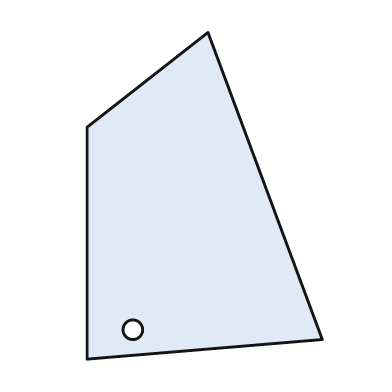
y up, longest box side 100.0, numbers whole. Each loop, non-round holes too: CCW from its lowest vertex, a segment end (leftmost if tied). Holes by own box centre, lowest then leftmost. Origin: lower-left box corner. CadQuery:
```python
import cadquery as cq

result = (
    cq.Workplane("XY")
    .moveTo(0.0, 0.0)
    .lineTo(72.0, 6.0)
    .lineTo(37.0, 100.0)
    .lineTo(0.0, 71.0)
    .close()
    .moveTo(14.0, 9.0)
    .circle(3.0)
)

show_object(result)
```